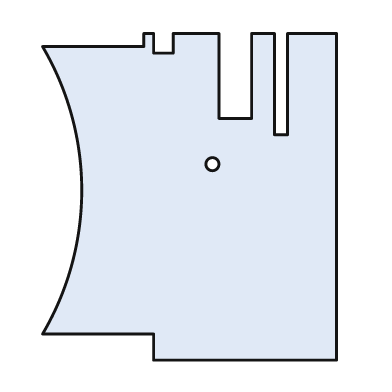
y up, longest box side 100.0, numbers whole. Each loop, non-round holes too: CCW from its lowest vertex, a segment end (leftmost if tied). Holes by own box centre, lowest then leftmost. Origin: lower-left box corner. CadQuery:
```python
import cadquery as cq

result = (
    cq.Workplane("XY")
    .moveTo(34.0, 0.0)
    .lineTo(90.0, 0.0)
    .lineTo(90.0, 100.0)
    .lineTo(75.0, 100.0)
    .lineTo(75.0, 69.0)
    .lineTo(71.0, 69.0)
    .lineTo(71.0, 100.0)
    .lineTo(64.0, 100.0)
    .lineTo(64.0, 74.0)
    .lineTo(54.0, 74.0)
    .lineTo(54.0, 100.0)
    .lineTo(40.0, 100.0)
    .lineTo(40.0, 94.0)
    .lineTo(34.0, 94.0)
    .lineTo(34.0, 100.0)
    .lineTo(31.0, 100.0)
    .lineTo(31.0, 96.0)
    .lineTo(0.0, 96.0)
    .threePointArc((12.0, 52.0), (0.0, 8.0))
    .lineTo(34.0, 8.0)
    .close()
    .moveTo(52.0, 60.0)
    .circle(2.0)
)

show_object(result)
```